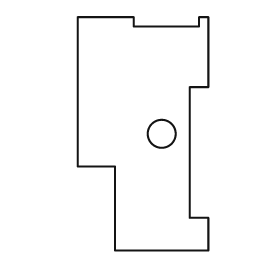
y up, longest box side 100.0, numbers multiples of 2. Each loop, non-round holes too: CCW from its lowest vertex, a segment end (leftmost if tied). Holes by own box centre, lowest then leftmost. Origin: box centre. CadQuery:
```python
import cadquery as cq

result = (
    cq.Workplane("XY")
    .moveTo(-12.0, -50.0)
    .lineTo(28.0, -50.0)
    .lineTo(28.0, -36.0)
    .lineTo(20.0, -36.0)
    .lineTo(20.0, 20.0)
    .lineTo(28.0, 20.0)
    .lineTo(28.0, 50.0)
    .lineTo(24.0, 50.0)
    .lineTo(24.0, 46.0)
    .lineTo(-4.0, 46.0)
    .lineTo(-4.0, 50.0)
    .lineTo(-28.0, 50.0)
    .lineTo(-28.0, -14.0)
    .lineTo(-12.0, -14.0)
    .close()
    .moveTo(8.0, 0.0)
    .circle(6.0)
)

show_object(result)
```